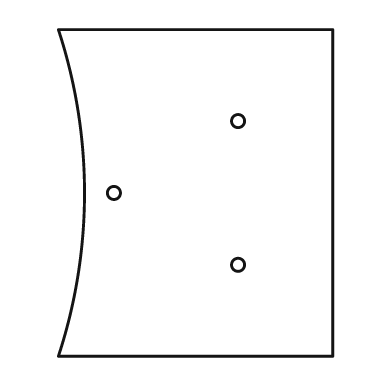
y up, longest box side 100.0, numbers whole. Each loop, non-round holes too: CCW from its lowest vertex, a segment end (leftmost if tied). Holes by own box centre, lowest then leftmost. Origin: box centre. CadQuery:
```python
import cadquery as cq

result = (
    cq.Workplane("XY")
    .moveTo(-42.0, -50.0)
    .lineTo(42.0, -50.0)
    .lineTo(42.0, 50.0)
    .lineTo(-42.0, 50.0)
    .threePointArc((-34.0, 0.0), (-42.0, -50.0))
    .close()
    .moveTo(13.0, -22.0)
    .circle(2.0)
    .moveTo(-25.0, 0.0)
    .circle(2.0)
    .moveTo(13.0, 22.0)
    .circle(2.0)
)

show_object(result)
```